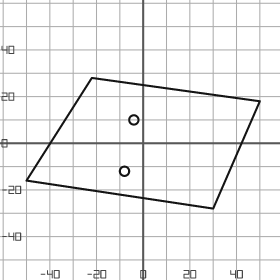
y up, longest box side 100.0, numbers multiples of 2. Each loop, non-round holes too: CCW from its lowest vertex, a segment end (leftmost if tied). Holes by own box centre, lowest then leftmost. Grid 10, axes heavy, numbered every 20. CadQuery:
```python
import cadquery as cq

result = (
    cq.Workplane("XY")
    .moveTo(30.0, -28.0)
    .lineTo(50.0, 18.0)
    .lineTo(-22.0, 28.0)
    .lineTo(-50.0, -16.0)
    .close()
    .moveTo(-8.0, -12.0)
    .circle(2.0)
    .moveTo(-4.0, 10.0)
    .circle(2.0)
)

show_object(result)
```